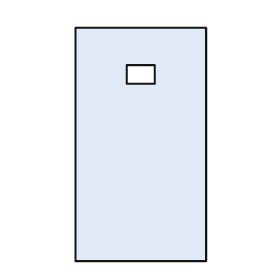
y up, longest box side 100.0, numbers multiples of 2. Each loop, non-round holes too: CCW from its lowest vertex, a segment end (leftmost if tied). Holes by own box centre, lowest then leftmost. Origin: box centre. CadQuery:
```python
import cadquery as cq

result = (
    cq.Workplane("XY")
    .moveTo(-28.0, -50.0)
    .lineTo(28.0, -50.0)
    .lineTo(28.0, 50.0)
    .lineTo(-28.0, 50.0)
    .close()
    .moveTo(-6.0, 26.0)
    .lineTo(6.0, 26.0)
    .lineTo(6.0, 34.0)
    .lineTo(-6.0, 34.0)
    .close()
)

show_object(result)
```